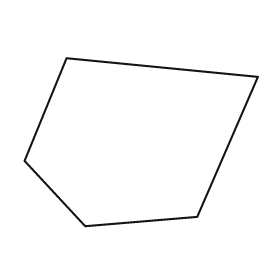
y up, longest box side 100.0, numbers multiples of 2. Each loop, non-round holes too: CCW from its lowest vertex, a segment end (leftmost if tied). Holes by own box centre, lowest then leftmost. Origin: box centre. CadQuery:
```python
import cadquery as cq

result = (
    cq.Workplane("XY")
    .moveTo(-24.0, -36.0)
    .lineTo(24.0, -32.0)
    .lineTo(50.0, 28.0)
    .lineTo(-32.0, 36.0)
    .lineTo(-50.0, -8.0)
    .close()
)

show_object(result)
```